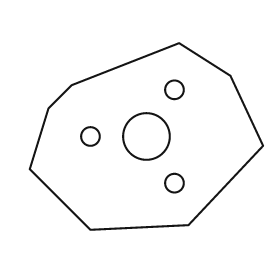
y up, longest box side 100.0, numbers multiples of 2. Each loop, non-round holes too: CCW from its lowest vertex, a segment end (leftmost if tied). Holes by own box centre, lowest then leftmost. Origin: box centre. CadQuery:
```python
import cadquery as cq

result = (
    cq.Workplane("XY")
    .moveTo(-24.0, -40.0)
    .lineTo(18.0, -38.0)
    .lineTo(50.0, -4.0)
    .lineTo(36.0, 26.0)
    .lineTo(14.0, 40.0)
    .lineTo(-32.0, 22.0)
    .lineTo(-42.0, 12.0)
    .lineTo(-50.0, -14.0)
    .close()
    .moveTo(12.0, -20.0)
    .circle(4.0)
    .moveTo(-24.0, 0.0)
    .circle(4.0)
    .moveTo(0.0, 0.0)
    .circle(10.0)
    .moveTo(12.0, 20.0)
    .circle(4.0)
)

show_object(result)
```